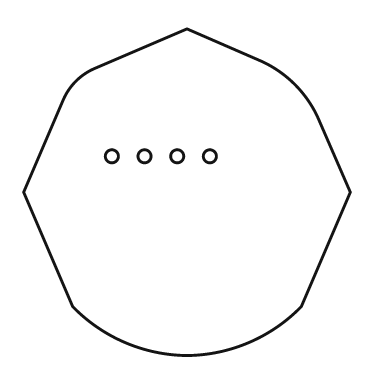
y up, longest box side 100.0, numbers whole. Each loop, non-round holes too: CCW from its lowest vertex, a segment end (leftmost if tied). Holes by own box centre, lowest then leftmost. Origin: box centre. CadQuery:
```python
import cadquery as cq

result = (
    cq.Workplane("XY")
    .moveTo(0.0, -50.0)
    .threePointArc((19.0, -46.0), (35.0, -35.0))
    .lineTo(50.0, 0.0)
    .lineTo(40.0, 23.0)
    .threePointArc((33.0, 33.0), (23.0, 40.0))
    .lineTo(0.0, 50.0)
    .lineTo(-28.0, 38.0)
    .threePointArc((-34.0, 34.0), (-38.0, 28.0))
    .lineTo(-50.0, 0.0)
    .lineTo(-35.0, -35.0)
    .threePointArc((-19.0, -46.0), (0.0, -50.0))
    .close()
    .moveTo(-23.0, 11.0)
    .circle(2.0)
    .moveTo(-13.0, 11.0)
    .circle(2.0)
    .moveTo(-3.0, 11.0)
    .circle(2.0)
    .moveTo(7.0, 11.0)
    .circle(2.0)
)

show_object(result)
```